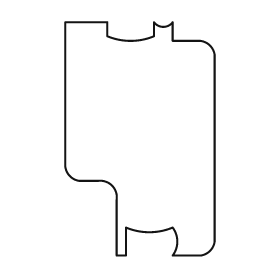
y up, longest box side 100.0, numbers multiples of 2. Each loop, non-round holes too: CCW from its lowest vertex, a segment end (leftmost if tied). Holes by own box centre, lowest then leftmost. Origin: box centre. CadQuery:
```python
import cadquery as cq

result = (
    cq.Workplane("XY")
    .moveTo(-10.0, -50.0)
    .lineTo(-6.0, -50.0)
    .lineTo(-6.0, -38.0)
    .threePointArc((4.0, -40.0), (14.0, -38.0))
    .threePointArc((16.0, -44.0), (14.0, -50.0))
    .lineTo(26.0, -50.0)
    .threePointArc((30.0, -48.0), (32.0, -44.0))
    .lineTo(32.0, 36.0)
    .threePointArc((30.0, 40.0), (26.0, 42.0))
    .lineTo(14.0, 42.0)
    .lineTo(14.0, 50.0)
    .threePointArc((10.0, 48.0), (6.0, 50.0))
    .lineTo(6.0, 44.0)
    .threePointArc((-4.0, 42.0), (-14.0, 44.0))
    .lineTo(-14.0, 50.0)
    .lineTo(-32.0, 50.0)
    .lineTo(-32.0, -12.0)
    .threePointArc((-30.0, -16.0), (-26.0, -18.0))
    .lineTo(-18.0, -18.0)
    .threePointArc((-12.0, -20.0), (-10.0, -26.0))
    .close()
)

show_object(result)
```